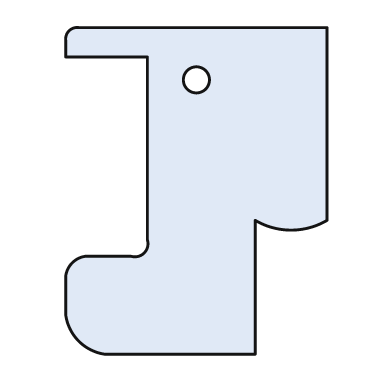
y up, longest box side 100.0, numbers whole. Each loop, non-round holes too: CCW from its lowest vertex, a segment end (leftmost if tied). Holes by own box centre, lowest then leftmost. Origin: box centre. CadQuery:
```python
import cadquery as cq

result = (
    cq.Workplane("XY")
    .moveTo(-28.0, -50.0)
    .lineTo(18.0, -50.0)
    .lineTo(18.0, -9.0)
    .threePointArc((29.0, -12.0), (40.0, -9.0))
    .lineTo(40.0, 50.0)
    .lineTo(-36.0, 50.0)
    .threePointArc((-39.0, 49.0), (-40.0, 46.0))
    .lineTo(-40.0, 41.0)
    .lineTo(-15.0, 41.0)
    .lineTo(-15.0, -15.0)
    .threePointArc((-16.0, -19.0), (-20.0, -20.0))
    .lineTo(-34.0, -20.0)
    .threePointArc((-38.0, -22.0), (-40.0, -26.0))
    .lineTo(-40.0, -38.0)
    .threePointArc((-36.0, -46.0), (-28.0, -50.0))
    .close()
    .moveTo(0.0, 34.0)
    .circle(4.0)
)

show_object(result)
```